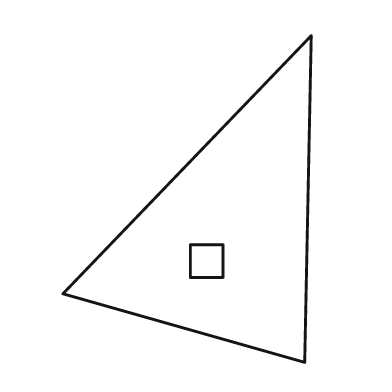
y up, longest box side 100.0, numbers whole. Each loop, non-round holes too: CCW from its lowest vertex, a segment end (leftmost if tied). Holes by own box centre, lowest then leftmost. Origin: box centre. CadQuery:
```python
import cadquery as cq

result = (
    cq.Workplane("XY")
    .moveTo(36.0, -50.0)
    .lineTo(38.0, 50.0)
    .lineTo(-38.0, -29.0)
    .close()
    .moveTo(1.0, -24.0)
    .lineTo(11.0, -24.0)
    .lineTo(11.0, -14.0)
    .lineTo(1.0, -14.0)
    .close()
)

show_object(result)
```